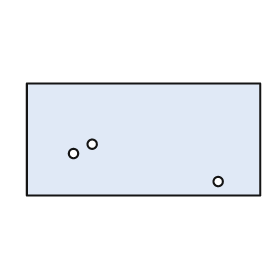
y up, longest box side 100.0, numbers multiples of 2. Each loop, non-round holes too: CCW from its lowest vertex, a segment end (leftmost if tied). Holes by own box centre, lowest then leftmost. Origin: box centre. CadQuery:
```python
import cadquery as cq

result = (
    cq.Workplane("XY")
    .moveTo(-50.0, -24.0)
    .lineTo(50.0, -24.0)
    .lineTo(50.0, 24.0)
    .lineTo(-50.0, 24.0)
    .close()
    .moveTo(32.0, -18.0)
    .circle(2.0)
    .moveTo(-30.0, -6.0)
    .circle(2.0)
    .moveTo(-22.0, -2.0)
    .circle(2.0)
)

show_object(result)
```